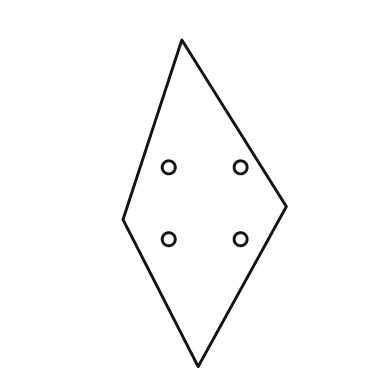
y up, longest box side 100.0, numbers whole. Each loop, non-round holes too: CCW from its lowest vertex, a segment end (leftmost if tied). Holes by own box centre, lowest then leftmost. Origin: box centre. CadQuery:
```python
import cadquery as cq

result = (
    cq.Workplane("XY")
    .moveTo(-2.0, -50.0)
    .lineTo(25.0, -1.0)
    .lineTo(-7.0, 50.0)
    .lineTo(-25.0, -5.0)
    .close()
    .moveTo(-11.0, -11.0)
    .circle(2.0)
    .moveTo(11.0, -11.0)
    .circle(2.0)
    .moveTo(-11.0, 11.0)
    .circle(2.0)
    .moveTo(11.0, 11.0)
    .circle(2.0)
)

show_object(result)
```